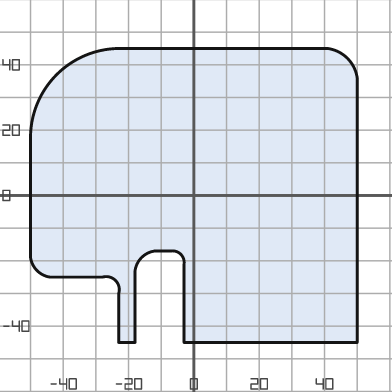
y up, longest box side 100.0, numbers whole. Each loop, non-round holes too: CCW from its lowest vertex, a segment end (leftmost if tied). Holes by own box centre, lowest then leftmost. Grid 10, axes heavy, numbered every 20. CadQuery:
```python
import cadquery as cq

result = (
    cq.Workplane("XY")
    .moveTo(-23.0, -45.0)
    .lineTo(-18.0, -45.0)
    .lineTo(-18.0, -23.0)
    .threePointArc((-16.0, -19.0), (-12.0, -17.0))
    .lineTo(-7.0, -17.0)
    .threePointArc((-4.0, -18.0), (-3.0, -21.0))
    .lineTo(-3.0, -45.0)
    .lineTo(50.0, -45.0)
    .lineTo(50.0, 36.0)
    .threePointArc((47.0, 42.0), (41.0, 45.0))
    .lineTo(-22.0, 45.0)
    .threePointArc((-42.0, 37.0), (-50.0, 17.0))
    .lineTo(-50.0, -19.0)
    .threePointArc((-48.0, -23.0), (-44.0, -25.0))
    .lineTo(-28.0, -25.0)
    .threePointArc((-24.0, -26.0), (-23.0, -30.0))
    .close()
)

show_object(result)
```